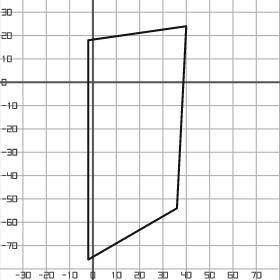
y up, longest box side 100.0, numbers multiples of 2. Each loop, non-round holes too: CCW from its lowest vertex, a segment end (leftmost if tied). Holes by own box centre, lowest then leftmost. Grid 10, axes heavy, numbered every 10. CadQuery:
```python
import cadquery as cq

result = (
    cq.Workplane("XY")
    .moveTo(-2.0, -76.0)
    .lineTo(36.0, -54.0)
    .lineTo(40.0, 24.0)
    .lineTo(-2.0, 18.0)
    .close()
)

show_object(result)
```